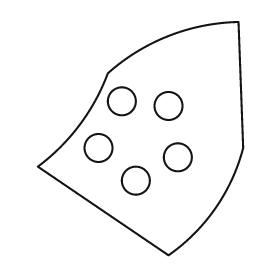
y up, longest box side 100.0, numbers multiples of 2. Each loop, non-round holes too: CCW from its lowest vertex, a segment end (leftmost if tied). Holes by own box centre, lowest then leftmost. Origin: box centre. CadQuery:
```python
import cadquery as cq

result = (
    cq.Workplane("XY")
    .moveTo(12.0, -50.0)
    .threePointArc((32.0, -30.0), (44.0, -4.0))
    .lineTo(42.0, 50.0)
    .threePointArc((12.0, 44.0), (-14.0, 28.0))
    .threePointArc((-26.0, 6.0), (-44.0, -12.0))
    .close()
    .moveTo(-2.0, -18.0)
    .circle(6.0)
    .moveTo(16.0, -8.0)
    .circle(6.0)
    .moveTo(-18.0, -4.0)
    .circle(6.0)
    .moveTo(12.0, 14.0)
    .circle(6.0)
    .moveTo(-8.0, 16.0)
    .circle(6.0)
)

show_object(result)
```